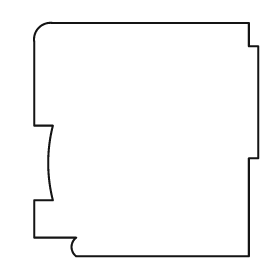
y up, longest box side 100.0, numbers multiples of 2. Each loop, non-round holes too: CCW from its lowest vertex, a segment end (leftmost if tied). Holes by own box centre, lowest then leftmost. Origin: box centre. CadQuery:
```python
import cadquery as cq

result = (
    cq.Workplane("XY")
    .moveTo(-30.0, -50.0)
    .lineTo(44.0, -50.0)
    .lineTo(44.0, -8.0)
    .lineTo(48.0, -8.0)
    .lineTo(48.0, 40.0)
    .lineTo(44.0, 40.0)
    .lineTo(44.0, 50.0)
    .lineTo(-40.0, 50.0)
    .threePointArc((-46.0, 48.0), (-48.0, 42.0))
    .lineTo(-48.0, 6.0)
    .lineTo(-40.0, 6.0)
    .threePointArc((-42.0, -10.0), (-40.0, -26.0))
    .lineTo(-48.0, -26.0)
    .lineTo(-48.0, -42.0)
    .lineTo(-30.0, -42.0)
    .threePointArc((-32.0, -46.0), (-30.0, -50.0))
    .close()
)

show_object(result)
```